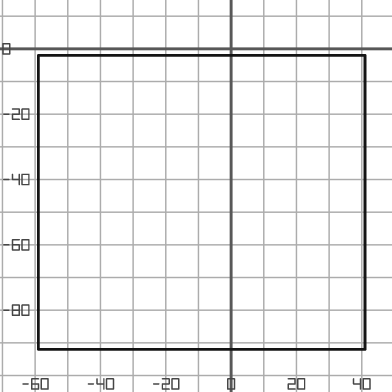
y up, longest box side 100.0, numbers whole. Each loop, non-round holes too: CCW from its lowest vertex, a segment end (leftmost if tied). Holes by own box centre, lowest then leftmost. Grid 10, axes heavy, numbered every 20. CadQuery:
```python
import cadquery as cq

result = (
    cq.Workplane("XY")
    .moveTo(-59.0, -92.0)
    .lineTo(41.0, -92.0)
    .lineTo(41.0, -2.0)
    .lineTo(-59.0, -2.0)
    .close()
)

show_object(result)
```